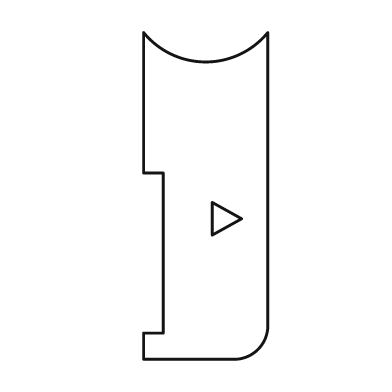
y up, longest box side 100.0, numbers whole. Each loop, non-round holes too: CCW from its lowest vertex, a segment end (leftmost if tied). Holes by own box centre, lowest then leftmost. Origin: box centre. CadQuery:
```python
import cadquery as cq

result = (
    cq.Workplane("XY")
    .moveTo(-19.0, -50.0)
    .lineTo(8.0, -50.0)
    .threePointArc((16.0, -47.0), (19.0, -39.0))
    .lineTo(19.0, 50.0)
    .threePointArc((0.0, 41.0), (-19.0, 50.0))
    .lineTo(-19.0, 7.0)
    .lineTo(-13.0, 7.0)
    .lineTo(-13.0, -42.0)
    .lineTo(-19.0, -42.0)
    .close()
    .moveTo(2.0, -12.0)
    .lineTo(11.0, -7.0)
    .lineTo(2.0, -2.0)
    .close()
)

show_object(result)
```